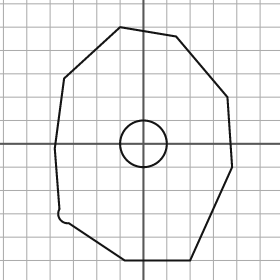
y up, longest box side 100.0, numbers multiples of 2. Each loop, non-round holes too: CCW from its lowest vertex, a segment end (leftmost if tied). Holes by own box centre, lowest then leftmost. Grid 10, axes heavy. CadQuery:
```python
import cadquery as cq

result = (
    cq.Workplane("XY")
    .moveTo(-8.0, -50.0)
    .lineTo(20.0, -50.0)
    .lineTo(38.0, -10.0)
    .lineTo(36.0, 20.0)
    .lineTo(14.0, 46.0)
    .lineTo(-10.0, 50.0)
    .lineTo(-34.0, 28.0)
    .lineTo(-38.0, -2.0)
    .lineTo(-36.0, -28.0)
    .threePointArc((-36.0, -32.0), (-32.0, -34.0))
    .close()
    .moveTo(0.0, 0.0)
    .circle(10.0)
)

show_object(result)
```